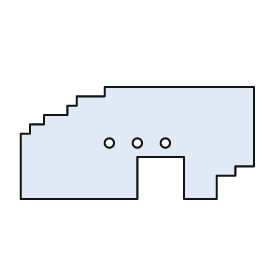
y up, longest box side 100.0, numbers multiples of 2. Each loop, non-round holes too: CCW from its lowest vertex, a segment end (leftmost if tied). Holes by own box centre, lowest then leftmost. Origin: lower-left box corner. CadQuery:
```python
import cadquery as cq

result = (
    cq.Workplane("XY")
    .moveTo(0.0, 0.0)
    .lineTo(50.0, 0.0)
    .lineTo(50.0, 18.0)
    .lineTo(70.0, 18.0)
    .lineTo(70.0, 0.0)
    .lineTo(84.0, 0.0)
    .lineTo(84.0, 10.0)
    .lineTo(92.0, 10.0)
    .lineTo(92.0, 14.0)
    .lineTo(100.0, 14.0)
    .lineTo(100.0, 48.0)
    .lineTo(36.0, 48.0)
    .lineTo(36.0, 44.0)
    .lineTo(24.0, 44.0)
    .lineTo(24.0, 40.0)
    .lineTo(20.0, 40.0)
    .lineTo(20.0, 36.0)
    .lineTo(10.0, 36.0)
    .lineTo(10.0, 32.0)
    .lineTo(4.0, 32.0)
    .lineTo(4.0, 28.0)
    .lineTo(0.0, 28.0)
    .close()
    .moveTo(38.0, 24.0)
    .circle(2.0)
    .moveTo(50.0, 24.0)
    .circle(2.0)
    .moveTo(62.0, 24.0)
    .circle(2.0)
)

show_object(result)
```